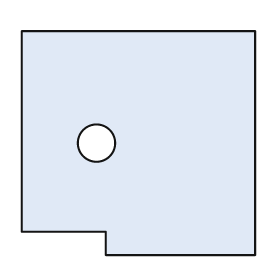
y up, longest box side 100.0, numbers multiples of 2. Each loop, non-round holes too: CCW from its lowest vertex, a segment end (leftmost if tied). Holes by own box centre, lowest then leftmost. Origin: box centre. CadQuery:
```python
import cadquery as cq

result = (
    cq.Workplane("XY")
    .moveTo(-14.0, -48.0)
    .lineTo(50.0, -48.0)
    .lineTo(50.0, 48.0)
    .lineTo(-50.0, 48.0)
    .lineTo(-50.0, -38.0)
    .lineTo(-14.0, -38.0)
    .close()
    .moveTo(-18.0, 0.0)
    .circle(8.0)
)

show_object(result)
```